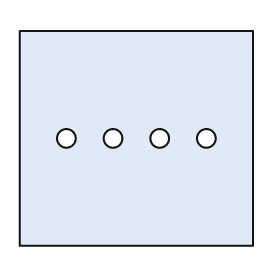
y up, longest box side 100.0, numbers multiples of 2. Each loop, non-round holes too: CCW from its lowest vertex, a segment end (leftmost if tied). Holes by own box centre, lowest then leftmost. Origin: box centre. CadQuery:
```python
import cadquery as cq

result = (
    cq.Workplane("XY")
    .moveTo(-50.0, -46.0)
    .lineTo(50.0, -46.0)
    .lineTo(50.0, 46.0)
    .lineTo(-50.0, 46.0)
    .close()
    .moveTo(-30.0, 0.0)
    .circle(4.0)
    .moveTo(-10.0, 0.0)
    .circle(4.0)
    .moveTo(10.0, 0.0)
    .circle(4.0)
    .moveTo(30.0, 0.0)
    .circle(4.0)
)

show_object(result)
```